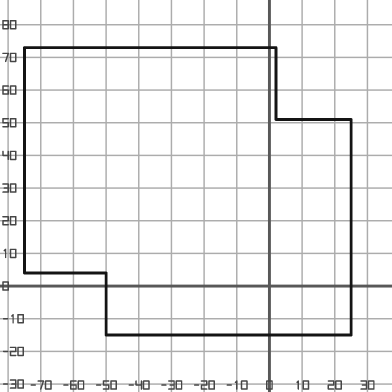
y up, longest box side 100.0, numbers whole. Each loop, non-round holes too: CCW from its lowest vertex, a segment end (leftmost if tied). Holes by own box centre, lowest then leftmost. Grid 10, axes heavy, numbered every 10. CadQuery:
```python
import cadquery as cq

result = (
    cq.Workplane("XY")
    .moveTo(-50.0, -15.0)
    .lineTo(25.0, -15.0)
    .lineTo(25.0, 51.0)
    .lineTo(2.0, 51.0)
    .lineTo(2.0, 73.0)
    .lineTo(-75.0, 73.0)
    .lineTo(-75.0, 4.0)
    .lineTo(-50.0, 4.0)
    .close()
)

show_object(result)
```